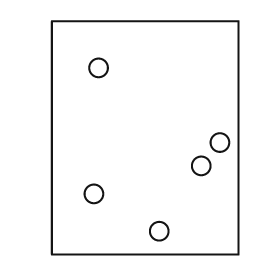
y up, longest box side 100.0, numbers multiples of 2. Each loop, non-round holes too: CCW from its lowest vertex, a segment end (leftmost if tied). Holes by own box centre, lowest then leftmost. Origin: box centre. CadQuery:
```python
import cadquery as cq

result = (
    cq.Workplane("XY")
    .moveTo(-40.0, -50.0)
    .lineTo(40.0, -50.0)
    .lineTo(40.0, 50.0)
    .lineTo(-40.0, 50.0)
    .close()
    .moveTo(6.0, -40.0)
    .circle(4.0)
    .moveTo(-22.0, -24.0)
    .circle(4.0)
    .moveTo(24.0, -12.0)
    .circle(4.0)
    .moveTo(32.0, -2.0)
    .circle(4.0)
    .moveTo(-20.0, 30.0)
    .circle(4.0)
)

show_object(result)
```